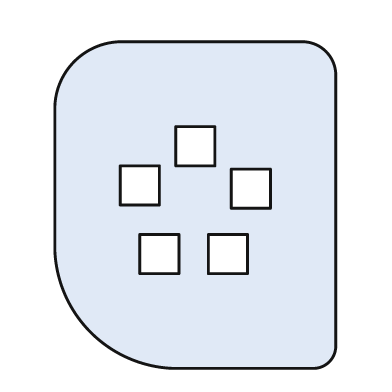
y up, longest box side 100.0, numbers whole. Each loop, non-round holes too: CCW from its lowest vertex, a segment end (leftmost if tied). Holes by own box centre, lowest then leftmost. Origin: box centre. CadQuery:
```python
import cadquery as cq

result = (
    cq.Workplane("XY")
    .moveTo(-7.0, -50.0)
    .lineTo(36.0, -50.0)
    .threePointArc((41.0, -48.0), (43.0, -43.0))
    .lineTo(43.0, 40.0)
    .threePointArc((40.0, 47.0), (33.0, 50.0))
    .lineTo(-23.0, 50.0)
    .threePointArc((-37.0, 44.0), (-43.0, 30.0))
    .lineTo(-43.0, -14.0)
    .threePointArc((-32.0, -39.0), (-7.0, -50.0))
    .close()
    .moveTo(-17.0, -21.0)
    .lineTo(-5.0, -21.0)
    .lineTo(-5.0, -9.0)
    .lineTo(-17.0, -9.0)
    .close()
    .moveTo(4.0, -21.0)
    .lineTo(16.0, -21.0)
    .lineTo(16.0, -9.0)
    .lineTo(4.0, -9.0)
    .close()
    .moveTo(11.0, -1.0)
    .lineTo(23.0, -1.0)
    .lineTo(23.0, 11.0)
    .lineTo(11.0, 11.0)
    .close()
    .moveTo(-23.0, 0.0)
    .lineTo(-11.0, 0.0)
    .lineTo(-11.0, 12.0)
    .lineTo(-23.0, 12.0)
    .close()
    .moveTo(-6.0, 12.0)
    .lineTo(6.0, 12.0)
    .lineTo(6.0, 24.0)
    .lineTo(-6.0, 24.0)
    .close()
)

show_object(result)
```